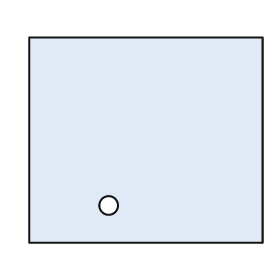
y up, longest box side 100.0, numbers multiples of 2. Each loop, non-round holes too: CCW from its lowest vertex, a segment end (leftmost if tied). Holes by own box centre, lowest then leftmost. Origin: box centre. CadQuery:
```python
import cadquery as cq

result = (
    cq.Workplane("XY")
    .moveTo(-50.0, -44.0)
    .lineTo(50.0, -44.0)
    .lineTo(50.0, 44.0)
    .lineTo(-50.0, 44.0)
    .close()
    .moveTo(-16.0, -28.0)
    .circle(4.0)
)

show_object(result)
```